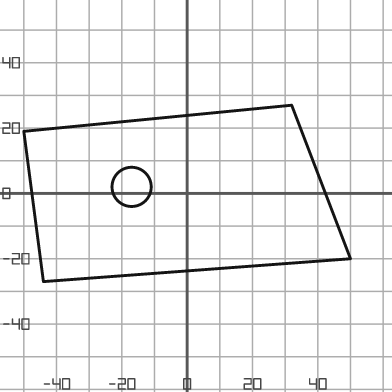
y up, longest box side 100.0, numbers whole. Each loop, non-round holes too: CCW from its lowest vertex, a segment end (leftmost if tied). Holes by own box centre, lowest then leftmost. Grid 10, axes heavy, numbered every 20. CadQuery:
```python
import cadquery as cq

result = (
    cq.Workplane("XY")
    .moveTo(-44.0, -27.0)
    .lineTo(50.0, -20.0)
    .lineTo(32.0, 27.0)
    .lineTo(-50.0, 19.0)
    .close()
    .moveTo(-17.0, 2.0)
    .circle(6.0)
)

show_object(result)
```